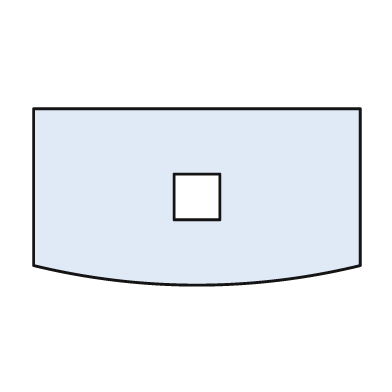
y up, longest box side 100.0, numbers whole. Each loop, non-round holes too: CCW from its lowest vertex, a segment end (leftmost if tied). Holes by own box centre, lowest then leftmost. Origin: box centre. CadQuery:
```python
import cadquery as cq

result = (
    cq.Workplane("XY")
    .moveTo(-50.0, -21.0)
    .threePointArc((0.0, -27.0), (50.0, -21.0))
    .lineTo(50.0, 27.0)
    .lineTo(-50.0, 27.0)
    .close()
    .moveTo(-7.0, -7.0)
    .lineTo(7.0, -7.0)
    .lineTo(7.0, 7.0)
    .lineTo(-7.0, 7.0)
    .close()
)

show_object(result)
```